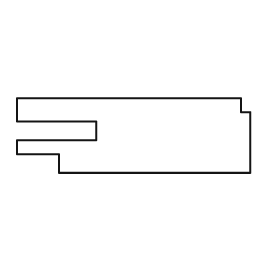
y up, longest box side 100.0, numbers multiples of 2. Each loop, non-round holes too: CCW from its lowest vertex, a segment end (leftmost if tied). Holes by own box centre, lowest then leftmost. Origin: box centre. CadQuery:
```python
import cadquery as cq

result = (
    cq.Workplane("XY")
    .moveTo(-32.0, -16.0)
    .lineTo(50.0, -16.0)
    .lineTo(50.0, 10.0)
    .lineTo(46.0, 10.0)
    .lineTo(46.0, 16.0)
    .lineTo(-50.0, 16.0)
    .lineTo(-50.0, 6.0)
    .lineTo(-16.0, 6.0)
    .lineTo(-16.0, -2.0)
    .lineTo(-50.0, -2.0)
    .lineTo(-50.0, -8.0)
    .lineTo(-32.0, -8.0)
    .close()
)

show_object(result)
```